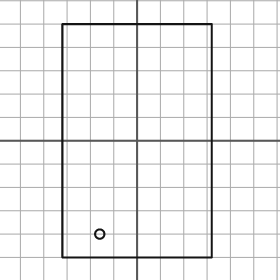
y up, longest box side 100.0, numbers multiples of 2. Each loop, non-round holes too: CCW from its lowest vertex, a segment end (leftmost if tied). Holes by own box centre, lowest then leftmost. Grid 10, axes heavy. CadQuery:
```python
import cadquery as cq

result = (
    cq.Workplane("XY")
    .moveTo(-32.0, -50.0)
    .lineTo(32.0, -50.0)
    .lineTo(32.0, 50.0)
    .lineTo(-32.0, 50.0)
    .close()
    .moveTo(-16.0, -40.0)
    .circle(2.0)
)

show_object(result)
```